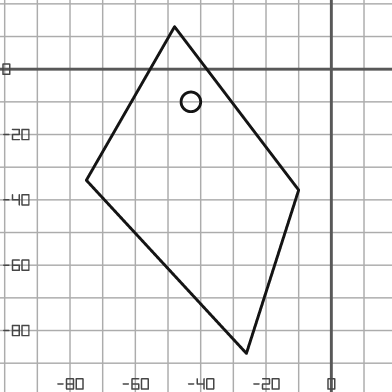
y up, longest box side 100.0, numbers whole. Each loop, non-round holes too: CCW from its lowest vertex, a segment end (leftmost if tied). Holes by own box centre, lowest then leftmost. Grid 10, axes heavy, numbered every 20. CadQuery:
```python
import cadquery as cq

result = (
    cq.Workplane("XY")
    .moveTo(-26.0, -87.0)
    .lineTo(-10.0, -37.0)
    .lineTo(-48.0, 13.0)
    .lineTo(-75.0, -34.0)
    .close()
    .moveTo(-43.0, -10.0)
    .circle(3.0)
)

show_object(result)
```